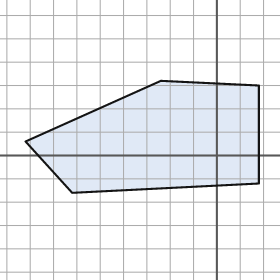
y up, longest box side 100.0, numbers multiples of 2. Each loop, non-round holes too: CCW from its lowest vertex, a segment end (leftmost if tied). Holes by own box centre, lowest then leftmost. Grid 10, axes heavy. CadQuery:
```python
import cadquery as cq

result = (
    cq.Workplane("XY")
    .moveTo(-62.0, -16.0)
    .lineTo(18.0, -12.0)
    .lineTo(18.0, 30.0)
    .lineTo(-24.0, 32.0)
    .lineTo(-82.0, 6.0)
    .close()
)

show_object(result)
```